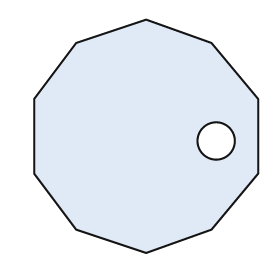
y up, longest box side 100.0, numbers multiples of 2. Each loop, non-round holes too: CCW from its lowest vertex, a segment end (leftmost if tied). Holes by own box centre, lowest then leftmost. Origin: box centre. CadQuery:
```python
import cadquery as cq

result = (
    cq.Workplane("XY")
    .moveTo(0.0, -50.0)
    .lineTo(28.0, -40.0)
    .lineTo(48.0, -16.0)
    .lineTo(48.0, 16.0)
    .lineTo(28.0, 40.0)
    .lineTo(0.0, 50.0)
    .lineTo(-30.0, 40.0)
    .lineTo(-48.0, 16.0)
    .lineTo(-48.0, -16.0)
    .lineTo(-30.0, -40.0)
    .close()
    .moveTo(30.0, -2.0)
    .circle(8.0)
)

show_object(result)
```